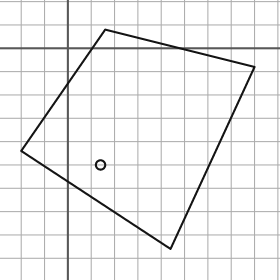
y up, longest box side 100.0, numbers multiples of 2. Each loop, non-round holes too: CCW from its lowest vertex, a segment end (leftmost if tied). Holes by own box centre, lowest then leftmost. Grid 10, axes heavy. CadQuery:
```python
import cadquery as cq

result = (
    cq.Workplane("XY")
    .moveTo(44.0, -86.0)
    .lineTo(80.0, -8.0)
    .lineTo(16.0, 8.0)
    .lineTo(-20.0, -44.0)
    .close()
    .moveTo(14.0, -50.0)
    .circle(2.0)
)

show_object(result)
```